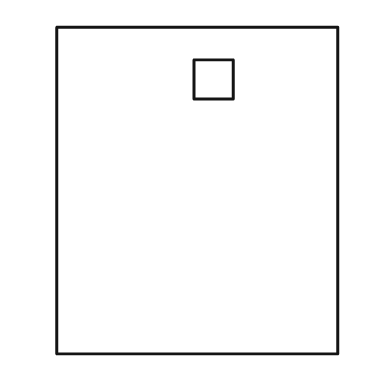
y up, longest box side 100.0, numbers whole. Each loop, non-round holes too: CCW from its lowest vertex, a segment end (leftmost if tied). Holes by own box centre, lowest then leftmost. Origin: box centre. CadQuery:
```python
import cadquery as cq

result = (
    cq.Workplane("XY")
    .moveTo(-43.0, -50.0)
    .lineTo(43.0, -50.0)
    .lineTo(43.0, 50.0)
    .lineTo(-43.0, 50.0)
    .close()
    .moveTo(-1.0, 28.0)
    .lineTo(11.0, 28.0)
    .lineTo(11.0, 40.0)
    .lineTo(-1.0, 40.0)
    .close()
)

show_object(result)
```